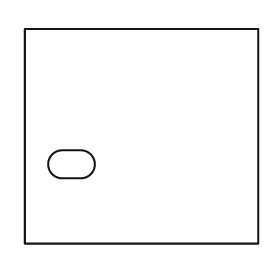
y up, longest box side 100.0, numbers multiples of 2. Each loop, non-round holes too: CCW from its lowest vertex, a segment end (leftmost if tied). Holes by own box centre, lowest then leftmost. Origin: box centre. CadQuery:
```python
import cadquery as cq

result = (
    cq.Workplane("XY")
    .moveTo(-50.0, -46.0)
    .lineTo(50.0, -46.0)
    .lineTo(50.0, 46.0)
    .lineTo(-50.0, 46.0)
    .close()
    .moveTo(-34.0, -18.0)
    .lineTo(-26.0, -18.0)
    .threePointArc((-20.0, -12.0), (-26.0, -6.0))
    .lineTo(-34.0, -6.0)
    .threePointArc((-40.0, -12.0), (-34.0, -18.0))
    .close()
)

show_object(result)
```